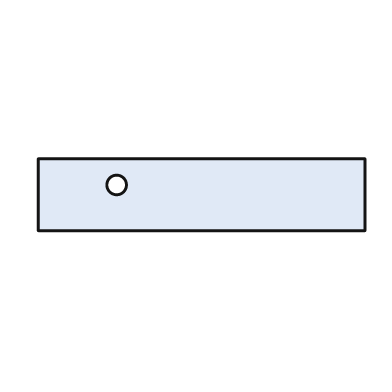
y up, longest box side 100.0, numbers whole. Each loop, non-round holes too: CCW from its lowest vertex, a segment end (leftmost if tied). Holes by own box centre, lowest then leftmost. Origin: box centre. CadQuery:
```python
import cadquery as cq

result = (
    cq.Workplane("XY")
    .moveTo(-50.0, -11.0)
    .lineTo(50.0, -11.0)
    .lineTo(50.0, 11.0)
    .lineTo(-50.0, 11.0)
    .close()
    .moveTo(-26.0, 3.0)
    .circle(3.0)
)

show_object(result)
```